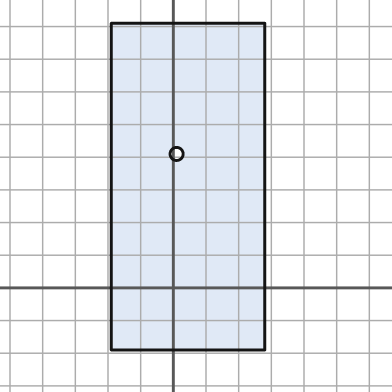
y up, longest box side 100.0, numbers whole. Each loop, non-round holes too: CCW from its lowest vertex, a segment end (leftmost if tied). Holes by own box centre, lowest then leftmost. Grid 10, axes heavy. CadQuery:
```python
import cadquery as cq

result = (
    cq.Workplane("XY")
    .moveTo(-19.0, -19.0)
    .lineTo(28.0, -19.0)
    .lineTo(28.0, 81.0)
    .lineTo(-19.0, 81.0)
    .close()
    .moveTo(1.0, 41.0)
    .circle(2.0)
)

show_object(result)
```